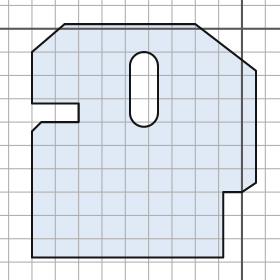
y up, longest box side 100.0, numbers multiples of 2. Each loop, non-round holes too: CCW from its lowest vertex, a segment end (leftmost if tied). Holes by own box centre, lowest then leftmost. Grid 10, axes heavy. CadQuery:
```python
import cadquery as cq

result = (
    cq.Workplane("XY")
    .moveTo(-90.0, -98.0)
    .lineTo(-8.0, -98.0)
    .lineTo(-8.0, -70.0)
    .lineTo(0.0, -70.0)
    .lineTo(6.0, -66.0)
    .lineTo(6.0, -18.0)
    .lineTo(-20.0, 2.0)
    .lineTo(-76.0, 2.0)
    .lineTo(-90.0, -10.0)
    .lineTo(-90.0, -32.0)
    .lineTo(-70.0, -32.0)
    .lineTo(-70.0, -40.0)
    .lineTo(-86.0, -40.0)
    .lineTo(-90.0, -44.0)
    .close()
    .moveTo(-48.0, -36.0)
    .threePointArc((-42.0, -42.0), (-36.0, -36.0))
    .lineTo(-36.0, -16.0)
    .threePointArc((-42.0, -10.0), (-48.0, -16.0))
    .close()
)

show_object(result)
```